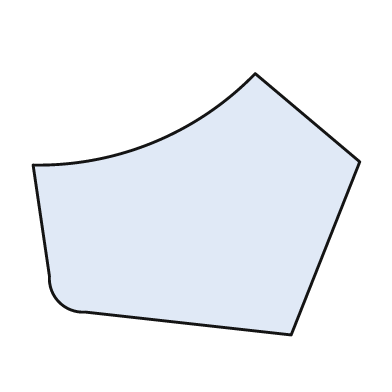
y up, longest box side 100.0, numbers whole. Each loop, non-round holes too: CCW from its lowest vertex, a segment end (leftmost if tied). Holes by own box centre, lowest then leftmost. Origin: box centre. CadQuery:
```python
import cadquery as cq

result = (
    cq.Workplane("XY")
    .moveTo(29.0, -40.0)
    .lineTo(50.0, 13.0)
    .lineTo(18.0, 40.0)
    .threePointArc((-13.0, 19.0), (-50.0, 12.0))
    .lineTo(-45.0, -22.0)
    .threePointArc((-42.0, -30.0), (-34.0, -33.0))
    .close()
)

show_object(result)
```